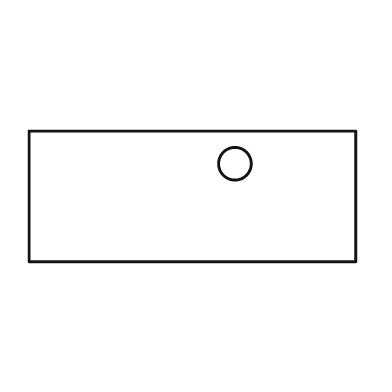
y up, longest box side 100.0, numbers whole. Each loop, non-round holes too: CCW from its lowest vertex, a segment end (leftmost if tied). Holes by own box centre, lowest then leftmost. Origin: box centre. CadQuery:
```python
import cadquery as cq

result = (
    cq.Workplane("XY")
    .moveTo(-50.0, -20.0)
    .lineTo(50.0, -20.0)
    .lineTo(50.0, 20.0)
    .lineTo(-50.0, 20.0)
    .close()
    .moveTo(13.0, 10.0)
    .circle(5.0)
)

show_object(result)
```